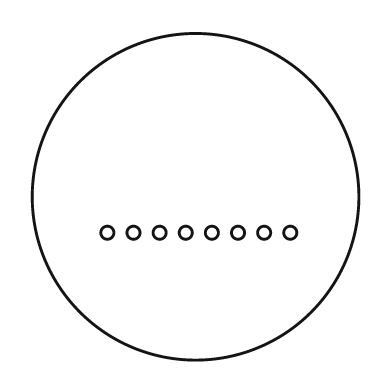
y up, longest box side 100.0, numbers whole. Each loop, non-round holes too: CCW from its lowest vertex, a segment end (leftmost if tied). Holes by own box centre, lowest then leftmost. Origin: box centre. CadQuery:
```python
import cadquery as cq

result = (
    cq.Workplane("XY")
    .moveTo(0.0, 0.0)
    .circle(50.0)
    .moveTo(-27.0, -11.0)
    .circle(2.0)
    .moveTo(-19.0, -11.0)
    .circle(2.0)
    .moveTo(-11.0, -11.0)
    .circle(2.0)
    .moveTo(-3.0, -11.0)
    .circle(2.0)
    .moveTo(5.0, -11.0)
    .circle(2.0)
    .moveTo(13.0, -11.0)
    .circle(2.0)
    .moveTo(21.0, -11.0)
    .circle(2.0)
    .moveTo(29.0, -11.0)
    .circle(2.0)
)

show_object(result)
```